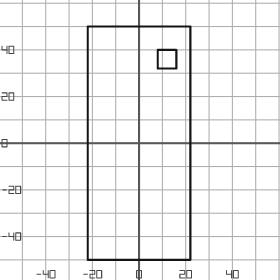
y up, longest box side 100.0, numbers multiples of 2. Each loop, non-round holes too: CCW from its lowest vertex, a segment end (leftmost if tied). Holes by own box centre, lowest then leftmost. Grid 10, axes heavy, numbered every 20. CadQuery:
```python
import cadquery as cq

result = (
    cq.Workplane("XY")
    .moveTo(-22.0, -50.0)
    .lineTo(22.0, -50.0)
    .lineTo(22.0, 50.0)
    .lineTo(-22.0, 50.0)
    .close()
    .moveTo(8.0, 32.0)
    .lineTo(16.0, 32.0)
    .lineTo(16.0, 40.0)
    .lineTo(8.0, 40.0)
    .close()
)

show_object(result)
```